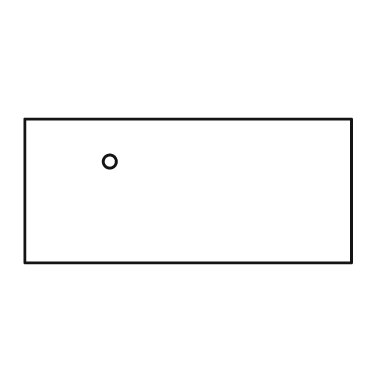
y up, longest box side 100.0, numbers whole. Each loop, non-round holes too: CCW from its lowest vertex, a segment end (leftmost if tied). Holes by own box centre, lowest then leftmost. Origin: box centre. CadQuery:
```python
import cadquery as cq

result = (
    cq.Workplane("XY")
    .moveTo(-50.0, -22.0)
    .lineTo(50.0, -22.0)
    .lineTo(50.0, 22.0)
    .lineTo(-50.0, 22.0)
    .close()
    .moveTo(-24.0, 9.0)
    .circle(2.0)
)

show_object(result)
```